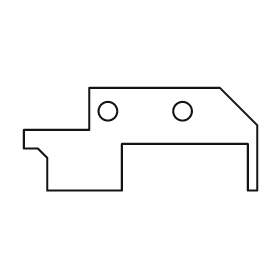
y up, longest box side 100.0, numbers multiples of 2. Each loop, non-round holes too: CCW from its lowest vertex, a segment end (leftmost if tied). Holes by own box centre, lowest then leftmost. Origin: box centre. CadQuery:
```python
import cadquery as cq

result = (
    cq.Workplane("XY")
    .moveTo(-40.0, -22.0)
    .lineTo(-8.0, -22.0)
    .lineTo(-8.0, -2.0)
    .lineTo(46.0, -2.0)
    .lineTo(46.0, -22.0)
    .lineTo(50.0, -22.0)
    .lineTo(50.0, 6.0)
    .lineTo(34.0, 22.0)
    .lineTo(-22.0, 22.0)
    .lineTo(-22.0, 4.0)
    .lineTo(-50.0, 4.0)
    .lineTo(-50.0, -4.0)
    .lineTo(-44.0, -4.0)
    .lineTo(-40.0, -8.0)
    .close()
    .moveTo(-14.0, 12.0)
    .circle(4.0)
    .moveTo(18.0, 12.0)
    .circle(4.0)
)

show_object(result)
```